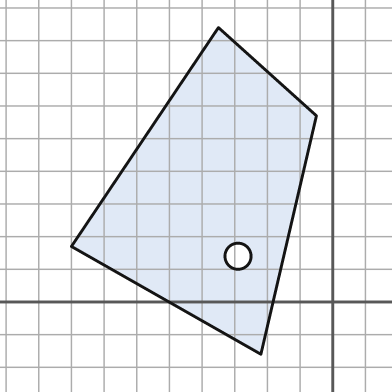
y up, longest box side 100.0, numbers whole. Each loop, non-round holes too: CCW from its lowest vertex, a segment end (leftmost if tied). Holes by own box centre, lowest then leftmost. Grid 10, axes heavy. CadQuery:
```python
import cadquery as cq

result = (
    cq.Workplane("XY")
    .moveTo(-22.0, -16.0)
    .lineTo(-5.0, 57.0)
    .lineTo(-35.0, 84.0)
    .lineTo(-80.0, 17.0)
    .close()
    .moveTo(-29.0, 14.0)
    .circle(4.0)
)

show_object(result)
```